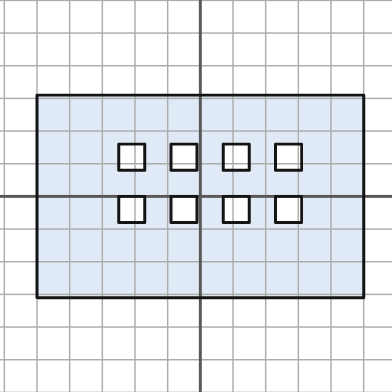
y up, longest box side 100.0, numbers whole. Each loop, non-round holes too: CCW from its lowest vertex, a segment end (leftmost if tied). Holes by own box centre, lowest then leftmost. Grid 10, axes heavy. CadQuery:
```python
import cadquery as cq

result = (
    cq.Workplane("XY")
    .moveTo(-50.0, -31.0)
    .lineTo(50.0, -31.0)
    .lineTo(50.0, 31.0)
    .lineTo(-50.0, 31.0)
    .close()
    .moveTo(-25.0, -8.0)
    .lineTo(-17.0, -8.0)
    .lineTo(-17.0, 0.0)
    .lineTo(-25.0, 0.0)
    .close()
    .moveTo(-9.0, -8.0)
    .lineTo(-1.0, -8.0)
    .lineTo(-1.0, 0.0)
    .lineTo(-9.0, 0.0)
    .close()
    .moveTo(7.0, -8.0)
    .lineTo(15.0, -8.0)
    .lineTo(15.0, 0.0)
    .lineTo(7.0, 0.0)
    .close()
    .moveTo(23.0, -8.0)
    .lineTo(31.0, -8.0)
    .lineTo(31.0, 0.0)
    .lineTo(23.0, 0.0)
    .close()
    .moveTo(-25.0, 8.0)
    .lineTo(-17.0, 8.0)
    .lineTo(-17.0, 16.0)
    .lineTo(-25.0, 16.0)
    .close()
    .moveTo(-9.0, 8.0)
    .lineTo(-1.0, 8.0)
    .lineTo(-1.0, 16.0)
    .lineTo(-9.0, 16.0)
    .close()
    .moveTo(7.0, 8.0)
    .lineTo(15.0, 8.0)
    .lineTo(15.0, 16.0)
    .lineTo(7.0, 16.0)
    .close()
    .moveTo(23.0, 8.0)
    .lineTo(31.0, 8.0)
    .lineTo(31.0, 16.0)
    .lineTo(23.0, 16.0)
    .close()
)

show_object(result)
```